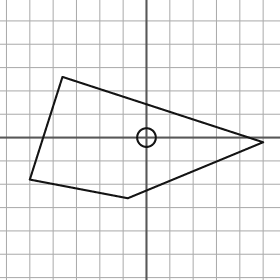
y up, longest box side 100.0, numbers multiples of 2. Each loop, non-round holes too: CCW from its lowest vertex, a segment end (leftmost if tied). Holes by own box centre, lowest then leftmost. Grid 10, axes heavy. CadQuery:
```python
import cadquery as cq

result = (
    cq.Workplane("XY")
    .moveTo(-8.0, -26.0)
    .lineTo(50.0, -2.0)
    .lineTo(-36.0, 26.0)
    .lineTo(-50.0, -18.0)
    .close()
    .moveTo(0.0, 0.0)
    .circle(4.0)
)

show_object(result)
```